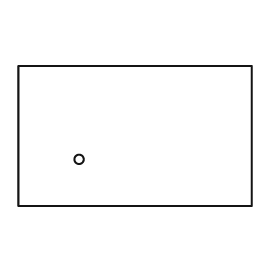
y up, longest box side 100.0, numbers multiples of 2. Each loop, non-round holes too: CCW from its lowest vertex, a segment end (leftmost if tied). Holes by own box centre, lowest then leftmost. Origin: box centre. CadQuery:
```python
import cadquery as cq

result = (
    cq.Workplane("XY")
    .moveTo(-50.0, -30.0)
    .lineTo(50.0, -30.0)
    .lineTo(50.0, 30.0)
    .lineTo(-50.0, 30.0)
    .close()
    .moveTo(-24.0, -10.0)
    .circle(2.0)
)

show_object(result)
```